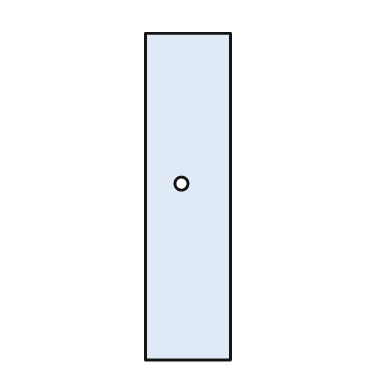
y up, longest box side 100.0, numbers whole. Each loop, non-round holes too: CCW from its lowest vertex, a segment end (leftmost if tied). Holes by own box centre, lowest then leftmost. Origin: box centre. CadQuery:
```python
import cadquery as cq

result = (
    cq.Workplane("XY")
    .moveTo(-13.0, -50.0)
    .lineTo(13.0, -50.0)
    .lineTo(13.0, 50.0)
    .lineTo(-13.0, 50.0)
    .close()
    .moveTo(-2.0, 4.0)
    .circle(2.0)
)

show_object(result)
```